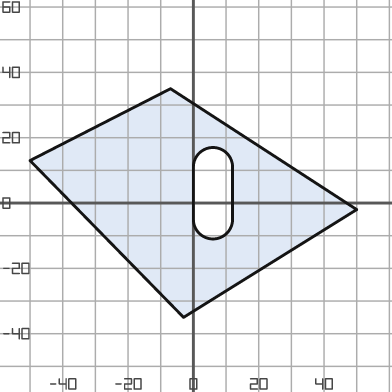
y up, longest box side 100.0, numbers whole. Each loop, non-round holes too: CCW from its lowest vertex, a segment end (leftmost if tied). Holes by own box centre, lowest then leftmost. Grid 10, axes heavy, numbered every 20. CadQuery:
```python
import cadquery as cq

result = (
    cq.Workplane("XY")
    .moveTo(-3.0, -35.0)
    .lineTo(50.0, -2.0)
    .lineTo(-7.0, 35.0)
    .lineTo(-50.0, 13.0)
    .close()
    .moveTo(0.0, -5.0)
    .threePointArc((6.0, -11.0), (12.0, -5.0))
    .lineTo(12.0, 11.0)
    .threePointArc((6.0, 17.0), (0.0, 11.0))
    .close()
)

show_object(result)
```